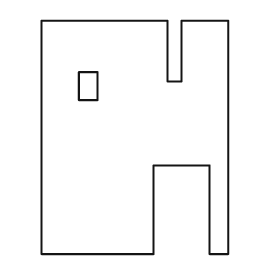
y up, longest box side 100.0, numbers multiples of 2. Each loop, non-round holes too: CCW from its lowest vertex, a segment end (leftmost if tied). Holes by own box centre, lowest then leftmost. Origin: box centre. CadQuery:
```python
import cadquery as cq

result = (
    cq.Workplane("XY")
    .moveTo(-40.0, -50.0)
    .lineTo(8.0, -50.0)
    .lineTo(8.0, -12.0)
    .lineTo(32.0, -12.0)
    .lineTo(32.0, -50.0)
    .lineTo(40.0, -50.0)
    .lineTo(40.0, 50.0)
    .lineTo(20.0, 50.0)
    .lineTo(20.0, 24.0)
    .lineTo(14.0, 24.0)
    .lineTo(14.0, 50.0)
    .lineTo(-40.0, 50.0)
    .close()
    .moveTo(-24.0, 16.0)
    .lineTo(-16.0, 16.0)
    .lineTo(-16.0, 28.0)
    .lineTo(-24.0, 28.0)
    .close()
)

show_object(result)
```